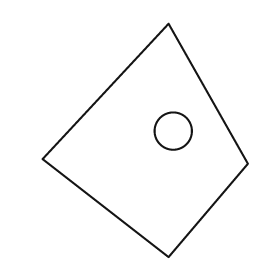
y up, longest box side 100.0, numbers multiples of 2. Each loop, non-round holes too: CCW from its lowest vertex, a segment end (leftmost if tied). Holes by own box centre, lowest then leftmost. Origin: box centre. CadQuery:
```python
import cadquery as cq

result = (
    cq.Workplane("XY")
    .moveTo(10.0, -50.0)
    .lineTo(44.0, -10.0)
    .lineTo(10.0, 50.0)
    .lineTo(-44.0, -8.0)
    .close()
    .moveTo(12.0, 4.0)
    .circle(8.0)
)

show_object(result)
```